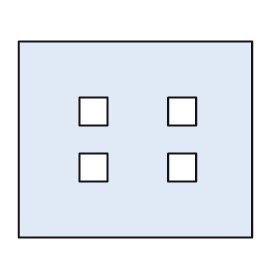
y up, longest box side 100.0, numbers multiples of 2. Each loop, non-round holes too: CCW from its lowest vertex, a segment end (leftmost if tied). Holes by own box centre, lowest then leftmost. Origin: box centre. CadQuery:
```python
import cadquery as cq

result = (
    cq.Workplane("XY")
    .moveTo(-50.0, -42.0)
    .lineTo(50.0, -42.0)
    .lineTo(50.0, 42.0)
    .lineTo(-50.0, 42.0)
    .close()
    .moveTo(-24.0, -18.0)
    .lineTo(-12.0, -18.0)
    .lineTo(-12.0, -6.0)
    .lineTo(-24.0, -6.0)
    .close()
    .moveTo(14.0, -18.0)
    .lineTo(26.0, -18.0)
    .lineTo(26.0, -6.0)
    .lineTo(14.0, -6.0)
    .close()
    .moveTo(-24.0, 6.0)
    .lineTo(-12.0, 6.0)
    .lineTo(-12.0, 18.0)
    .lineTo(-24.0, 18.0)
    .close()
    .moveTo(14.0, 6.0)
    .lineTo(26.0, 6.0)
    .lineTo(26.0, 18.0)
    .lineTo(14.0, 18.0)
    .close()
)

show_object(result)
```